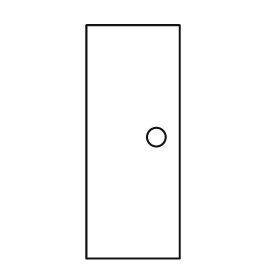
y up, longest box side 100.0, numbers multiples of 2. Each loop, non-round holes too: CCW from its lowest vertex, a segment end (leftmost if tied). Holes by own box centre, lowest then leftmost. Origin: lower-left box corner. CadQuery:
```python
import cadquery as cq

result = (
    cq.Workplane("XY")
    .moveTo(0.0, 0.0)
    .lineTo(40.0, 0.0)
    .lineTo(40.0, 100.0)
    .lineTo(0.0, 100.0)
    .close()
    .moveTo(30.0, 52.0)
    .circle(4.0)
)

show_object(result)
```